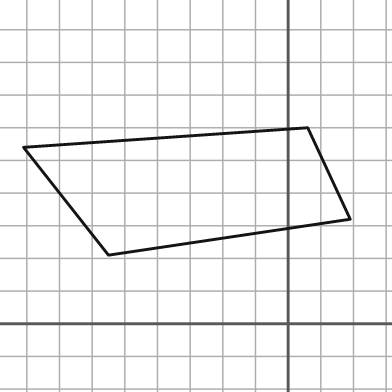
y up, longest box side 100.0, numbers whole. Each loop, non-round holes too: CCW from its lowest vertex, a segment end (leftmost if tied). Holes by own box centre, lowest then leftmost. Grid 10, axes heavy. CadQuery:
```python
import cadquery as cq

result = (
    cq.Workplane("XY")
    .moveTo(-55.0, 21.0)
    .lineTo(19.0, 32.0)
    .lineTo(6.0, 60.0)
    .lineTo(-81.0, 54.0)
    .close()
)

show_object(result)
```